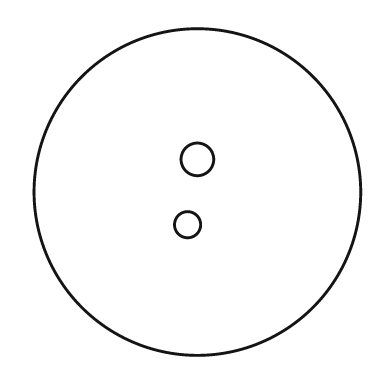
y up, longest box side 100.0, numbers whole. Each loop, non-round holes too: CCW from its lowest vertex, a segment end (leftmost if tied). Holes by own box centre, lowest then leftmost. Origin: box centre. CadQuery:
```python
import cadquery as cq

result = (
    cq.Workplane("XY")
    .moveTo(0.0, 0.0)
    .circle(50.0)
    .moveTo(-3.0, -10.0)
    .circle(4.0)
    .moveTo(0.0, 10.0)
    .circle(5.0)
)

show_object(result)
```